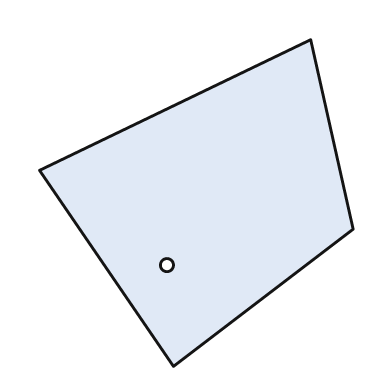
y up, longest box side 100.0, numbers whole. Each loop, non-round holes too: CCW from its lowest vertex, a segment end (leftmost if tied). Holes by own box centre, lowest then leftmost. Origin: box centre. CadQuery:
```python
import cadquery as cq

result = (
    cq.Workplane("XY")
    .moveTo(-7.0, -50.0)
    .lineTo(48.0, -8.0)
    .lineTo(35.0, 50.0)
    .lineTo(-48.0, 10.0)
    .close()
    .moveTo(-9.0, -19.0)
    .circle(2.0)
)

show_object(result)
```